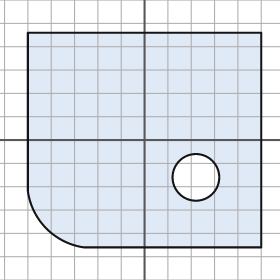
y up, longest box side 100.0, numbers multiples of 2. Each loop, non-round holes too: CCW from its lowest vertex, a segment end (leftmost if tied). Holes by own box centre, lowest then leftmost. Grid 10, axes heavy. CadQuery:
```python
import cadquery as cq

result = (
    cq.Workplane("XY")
    .moveTo(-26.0, -46.0)
    .lineTo(50.0, -46.0)
    .lineTo(50.0, 46.0)
    .lineTo(-50.0, 46.0)
    .lineTo(-50.0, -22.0)
    .threePointArc((-42.0, -38.0), (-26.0, -46.0))
    .close()
    .moveTo(22.0, -16.0)
    .circle(10.0)
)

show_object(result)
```